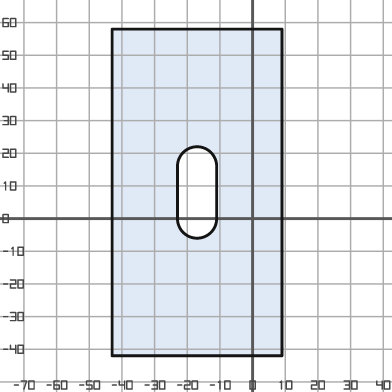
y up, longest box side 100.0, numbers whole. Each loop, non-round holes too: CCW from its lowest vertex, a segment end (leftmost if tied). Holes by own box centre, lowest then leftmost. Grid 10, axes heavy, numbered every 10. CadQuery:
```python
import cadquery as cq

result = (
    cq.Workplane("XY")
    .moveTo(-43.0, -42.0)
    .lineTo(9.0, -42.0)
    .lineTo(9.0, 58.0)
    .lineTo(-43.0, 58.0)
    .close()
    .moveTo(-23.0, 0.0)
    .threePointArc((-17.0, -6.0), (-11.0, 0.0))
    .lineTo(-11.0, 16.0)
    .threePointArc((-17.0, 22.0), (-23.0, 16.0))
    .close()
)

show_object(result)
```